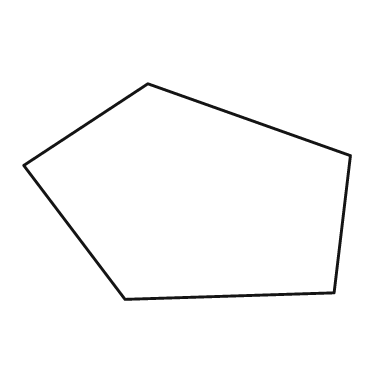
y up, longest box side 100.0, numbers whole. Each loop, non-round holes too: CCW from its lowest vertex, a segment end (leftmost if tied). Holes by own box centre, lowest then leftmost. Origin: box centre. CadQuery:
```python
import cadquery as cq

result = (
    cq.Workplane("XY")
    .moveTo(-19.0, -33.0)
    .lineTo(45.0, -31.0)
    .lineTo(50.0, 11.0)
    .lineTo(-12.0, 33.0)
    .lineTo(-50.0, 8.0)
    .close()
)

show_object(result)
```